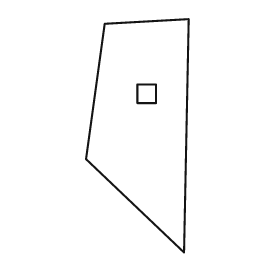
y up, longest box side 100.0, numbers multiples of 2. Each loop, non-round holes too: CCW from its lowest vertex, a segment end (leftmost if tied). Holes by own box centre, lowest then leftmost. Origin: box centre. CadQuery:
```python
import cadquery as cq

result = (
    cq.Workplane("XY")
    .moveTo(20.0, -50.0)
    .lineTo(22.0, 50.0)
    .lineTo(-14.0, 48.0)
    .lineTo(-22.0, -10.0)
    .close()
    .moveTo(0.0, 14.0)
    .lineTo(8.0, 14.0)
    .lineTo(8.0, 22.0)
    .lineTo(0.0, 22.0)
    .close()
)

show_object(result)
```